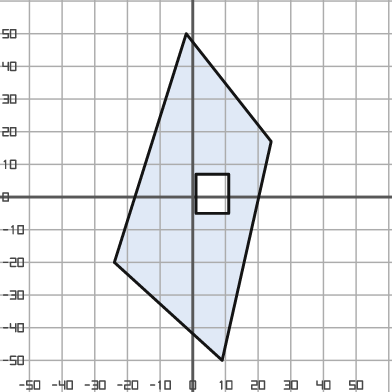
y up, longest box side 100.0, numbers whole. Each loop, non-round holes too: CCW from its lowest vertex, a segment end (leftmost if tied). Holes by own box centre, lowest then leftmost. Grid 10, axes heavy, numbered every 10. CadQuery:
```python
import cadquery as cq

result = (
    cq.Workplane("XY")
    .moveTo(9.0, -50.0)
    .lineTo(24.0, 17.0)
    .lineTo(-2.0, 50.0)
    .lineTo(-24.0, -20.0)
    .close()
    .moveTo(1.0, -5.0)
    .lineTo(11.0, -5.0)
    .lineTo(11.0, 7.0)
    .lineTo(1.0, 7.0)
    .close()
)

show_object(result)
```